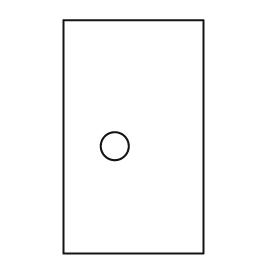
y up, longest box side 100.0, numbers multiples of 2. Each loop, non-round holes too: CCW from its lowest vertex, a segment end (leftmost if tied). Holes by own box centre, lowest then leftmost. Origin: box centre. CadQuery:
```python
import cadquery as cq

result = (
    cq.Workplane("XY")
    .moveTo(-30.0, -50.0)
    .lineTo(30.0, -50.0)
    .lineTo(30.0, 50.0)
    .lineTo(-30.0, 50.0)
    .close()
    .moveTo(-8.0, -4.0)
    .circle(6.0)
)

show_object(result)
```